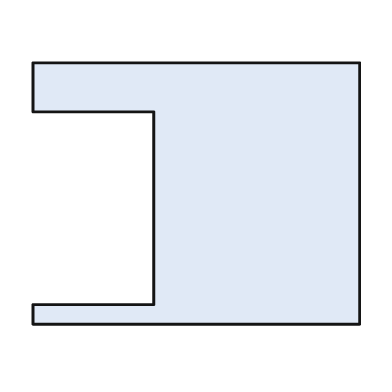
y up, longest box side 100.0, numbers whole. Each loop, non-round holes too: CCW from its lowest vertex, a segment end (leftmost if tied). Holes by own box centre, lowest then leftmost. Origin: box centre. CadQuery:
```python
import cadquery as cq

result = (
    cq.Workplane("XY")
    .moveTo(-50.0, -40.0)
    .lineTo(50.0, -40.0)
    .lineTo(50.0, 40.0)
    .lineTo(-50.0, 40.0)
    .lineTo(-50.0, 25.0)
    .lineTo(-13.0, 25.0)
    .lineTo(-13.0, -34.0)
    .lineTo(-50.0, -34.0)
    .close()
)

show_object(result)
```